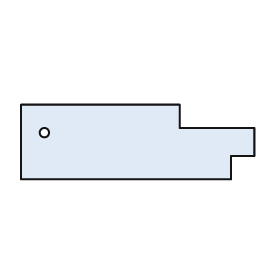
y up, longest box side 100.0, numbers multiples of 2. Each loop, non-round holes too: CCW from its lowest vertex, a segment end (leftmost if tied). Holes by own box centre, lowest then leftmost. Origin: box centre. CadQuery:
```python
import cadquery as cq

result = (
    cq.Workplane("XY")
    .moveTo(-50.0, -16.0)
    .lineTo(40.0, -16.0)
    .lineTo(40.0, -6.0)
    .lineTo(50.0, -6.0)
    .lineTo(50.0, 6.0)
    .lineTo(18.0, 6.0)
    .lineTo(18.0, 16.0)
    .lineTo(-50.0, 16.0)
    .close()
    .moveTo(-40.0, 4.0)
    .circle(2.0)
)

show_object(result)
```